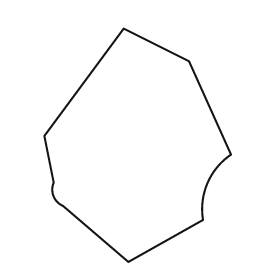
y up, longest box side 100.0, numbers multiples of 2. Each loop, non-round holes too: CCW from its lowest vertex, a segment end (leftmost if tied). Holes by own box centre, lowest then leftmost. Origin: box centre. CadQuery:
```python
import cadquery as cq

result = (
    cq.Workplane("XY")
    .moveTo(-4.0, -50.0)
    .lineTo(28.0, -32.0)
    .threePointArc((30.0, -16.0), (40.0, -4.0))
    .lineTo(22.0, 36.0)
    .lineTo(-6.0, 50.0)
    .lineTo(-40.0, 4.0)
    .lineTo(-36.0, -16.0)
    .threePointArc((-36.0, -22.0), (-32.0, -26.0))
    .close()
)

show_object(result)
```